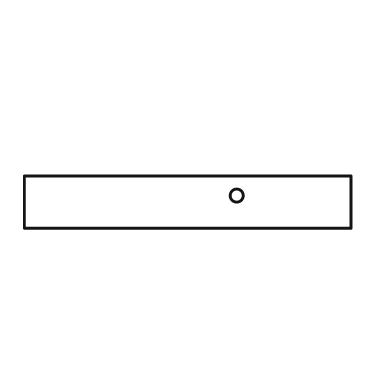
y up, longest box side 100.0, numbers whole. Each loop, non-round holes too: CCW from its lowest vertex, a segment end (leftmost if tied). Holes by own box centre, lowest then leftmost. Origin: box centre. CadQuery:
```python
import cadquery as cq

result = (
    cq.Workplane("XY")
    .moveTo(-50.0, -8.0)
    .lineTo(50.0, -8.0)
    .lineTo(50.0, 8.0)
    .lineTo(-50.0, 8.0)
    .close()
    .moveTo(15.0, 2.0)
    .circle(2.0)
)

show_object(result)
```